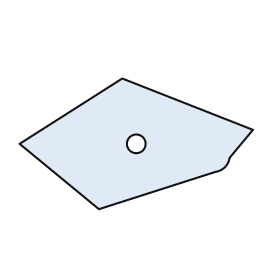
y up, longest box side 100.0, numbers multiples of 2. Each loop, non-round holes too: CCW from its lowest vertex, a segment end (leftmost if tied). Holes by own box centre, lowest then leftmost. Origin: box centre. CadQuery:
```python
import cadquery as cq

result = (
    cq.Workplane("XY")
    .moveTo(-16.0, -28.0)
    .lineTo(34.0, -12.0)
    .threePointArc((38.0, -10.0), (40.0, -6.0))
    .lineTo(50.0, 6.0)
    .lineTo(-6.0, 28.0)
    .lineTo(-50.0, 0.0)
    .close()
    .moveTo(0.0, 0.0)
    .circle(4.0)
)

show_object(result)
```